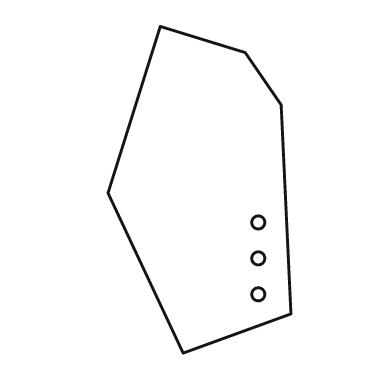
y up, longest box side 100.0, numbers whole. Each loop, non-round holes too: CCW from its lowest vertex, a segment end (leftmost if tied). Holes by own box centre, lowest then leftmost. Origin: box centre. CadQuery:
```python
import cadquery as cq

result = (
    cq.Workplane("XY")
    .moveTo(-5.0, -50.0)
    .lineTo(28.0, -38.0)
    .lineTo(25.0, 26.0)
    .lineTo(14.0, 42.0)
    .lineTo(-12.0, 50.0)
    .lineTo(-28.0, -1.0)
    .close()
    .moveTo(18.0, -32.0)
    .circle(2.0)
    .moveTo(18.0, -21.0)
    .circle(2.0)
    .moveTo(18.0, -10.0)
    .circle(2.0)
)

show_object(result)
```